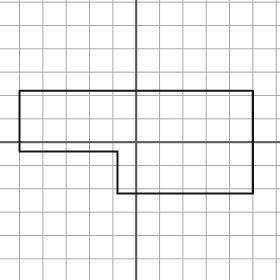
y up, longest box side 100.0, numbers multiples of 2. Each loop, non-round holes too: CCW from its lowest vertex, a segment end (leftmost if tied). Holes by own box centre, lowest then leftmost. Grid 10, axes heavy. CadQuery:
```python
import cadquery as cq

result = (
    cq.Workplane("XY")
    .moveTo(-8.0, -22.0)
    .lineTo(50.0, -22.0)
    .lineTo(50.0, 22.0)
    .lineTo(-50.0, 22.0)
    .lineTo(-50.0, -4.0)
    .lineTo(-8.0, -4.0)
    .close()
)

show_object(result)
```